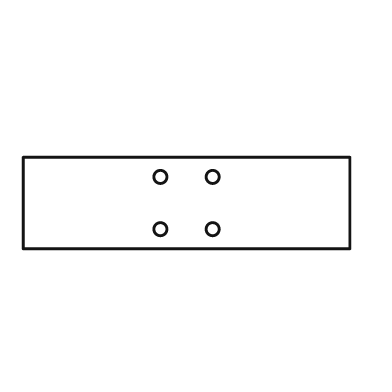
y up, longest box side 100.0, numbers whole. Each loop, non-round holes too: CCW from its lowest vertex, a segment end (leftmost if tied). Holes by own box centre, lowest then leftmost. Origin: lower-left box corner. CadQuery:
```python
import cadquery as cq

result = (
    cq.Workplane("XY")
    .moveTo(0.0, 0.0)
    .lineTo(100.0, 0.0)
    .lineTo(100.0, 28.0)
    .lineTo(0.0, 28.0)
    .close()
    .moveTo(42.0, 6.0)
    .circle(2.0)
    .moveTo(58.0, 6.0)
    .circle(2.0)
    .moveTo(42.0, 22.0)
    .circle(2.0)
    .moveTo(58.0, 22.0)
    .circle(2.0)
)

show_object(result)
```